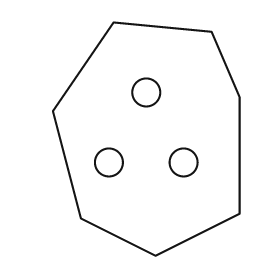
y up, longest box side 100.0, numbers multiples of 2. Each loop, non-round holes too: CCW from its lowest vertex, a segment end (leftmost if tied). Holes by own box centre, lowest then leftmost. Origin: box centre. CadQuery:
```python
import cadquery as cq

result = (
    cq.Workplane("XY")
    .moveTo(4.0, -50.0)
    .lineTo(40.0, -32.0)
    .lineTo(40.0, 18.0)
    .lineTo(28.0, 46.0)
    .lineTo(-14.0, 50.0)
    .lineTo(-40.0, 12.0)
    .lineTo(-28.0, -34.0)
    .close()
    .moveTo(-16.0, -10.0)
    .circle(6.0)
    .moveTo(16.0, -10.0)
    .circle(6.0)
    .moveTo(0.0, 20.0)
    .circle(6.0)
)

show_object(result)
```